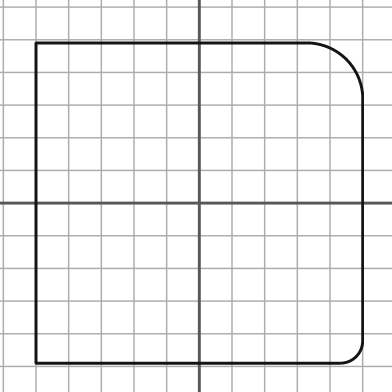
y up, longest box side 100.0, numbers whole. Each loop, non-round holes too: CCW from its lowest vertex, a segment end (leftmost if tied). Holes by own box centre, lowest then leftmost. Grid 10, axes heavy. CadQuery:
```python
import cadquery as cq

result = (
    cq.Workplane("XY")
    .moveTo(-50.0, -49.0)
    .lineTo(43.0, -49.0)
    .threePointArc((48.0, -47.0), (50.0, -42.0))
    .lineTo(50.0, 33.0)
    .threePointArc((45.0, 44.0), (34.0, 49.0))
    .lineTo(-50.0, 49.0)
    .close()
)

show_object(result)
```